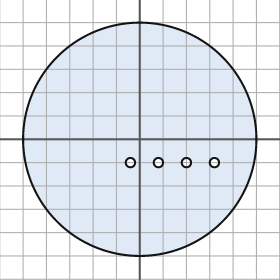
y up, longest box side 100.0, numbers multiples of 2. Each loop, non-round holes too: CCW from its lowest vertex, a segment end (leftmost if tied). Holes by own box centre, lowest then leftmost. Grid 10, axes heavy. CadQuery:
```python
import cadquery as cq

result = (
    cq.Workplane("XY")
    .moveTo(0.0, 0.0)
    .circle(50.0)
    .moveTo(-4.0, -10.0)
    .circle(2.0)
    .moveTo(8.0, -10.0)
    .circle(2.0)
    .moveTo(20.0, -10.0)
    .circle(2.0)
    .moveTo(32.0, -10.0)
    .circle(2.0)
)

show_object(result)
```